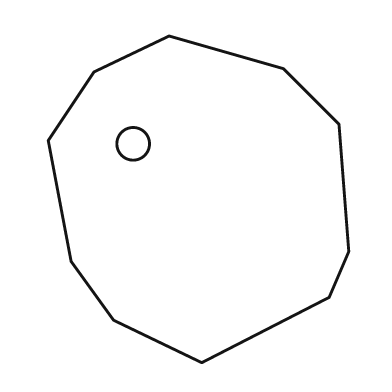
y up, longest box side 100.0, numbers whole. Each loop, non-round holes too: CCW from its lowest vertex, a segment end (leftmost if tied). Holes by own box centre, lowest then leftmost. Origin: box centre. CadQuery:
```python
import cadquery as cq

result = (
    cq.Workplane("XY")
    .moveTo(1.0, -50.0)
    .lineTo(40.0, -30.0)
    .lineTo(46.0, -16.0)
    .lineTo(43.0, 23.0)
    .lineTo(26.0, 40.0)
    .lineTo(-9.0, 50.0)
    .lineTo(-32.0, 39.0)
    .lineTo(-46.0, 18.0)
    .lineTo(-39.0, -19.0)
    .lineTo(-26.0, -37.0)
    .close()
    .moveTo(-20.0, 17.0)
    .circle(5.0)
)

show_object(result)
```